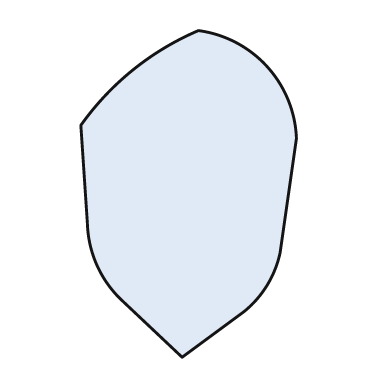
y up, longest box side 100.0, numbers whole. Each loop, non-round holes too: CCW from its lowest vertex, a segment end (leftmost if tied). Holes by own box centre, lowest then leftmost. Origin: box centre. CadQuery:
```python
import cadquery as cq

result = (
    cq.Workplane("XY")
    .moveTo(-2.0, -50.0)
    .lineTo(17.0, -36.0)
    .threePointArc((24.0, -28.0), (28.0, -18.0))
    .lineTo(33.0, 17.0)
    .threePointArc((24.0, 39.0), (3.0, 50.0))
    .threePointArc((-17.0, 38.0), (-33.0, 21.0))
    .lineTo(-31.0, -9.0)
    .threePointArc((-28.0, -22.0), (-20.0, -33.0))
    .close()
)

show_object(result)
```